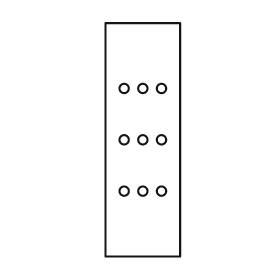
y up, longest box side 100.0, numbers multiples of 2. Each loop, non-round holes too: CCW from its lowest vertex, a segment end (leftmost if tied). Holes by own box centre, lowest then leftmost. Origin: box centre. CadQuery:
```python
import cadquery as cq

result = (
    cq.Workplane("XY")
    .moveTo(-16.0, -50.0)
    .lineTo(16.0, -50.0)
    .lineTo(16.0, 50.0)
    .lineTo(-16.0, 50.0)
    .close()
    .moveTo(-8.0, -22.0)
    .circle(2.0)
    .moveTo(0.0, -22.0)
    .circle(2.0)
    .moveTo(8.0, -22.0)
    .circle(2.0)
    .moveTo(-8.0, 0.0)
    .circle(2.0)
    .moveTo(0.0, 0.0)
    .circle(2.0)
    .moveTo(8.0, 0.0)
    .circle(2.0)
    .moveTo(-8.0, 22.0)
    .circle(2.0)
    .moveTo(0.0, 22.0)
    .circle(2.0)
    .moveTo(8.0, 22.0)
    .circle(2.0)
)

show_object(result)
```